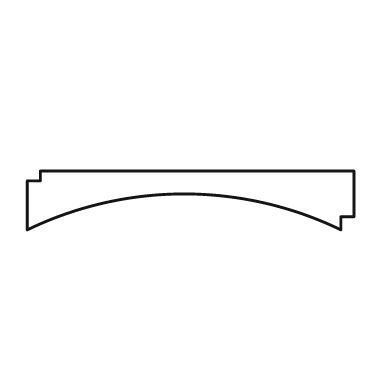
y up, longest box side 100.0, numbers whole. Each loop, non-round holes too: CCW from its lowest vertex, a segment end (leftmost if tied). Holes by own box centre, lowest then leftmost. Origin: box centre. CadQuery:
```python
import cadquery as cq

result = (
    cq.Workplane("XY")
    .moveTo(-50.0, -9.0)
    .threePointArc((-2.0, 2.0), (46.0, -9.0))
    .lineTo(46.0, -5.0)
    .lineTo(50.0, -5.0)
    .lineTo(50.0, 9.0)
    .lineTo(-46.0, 9.0)
    .lineTo(-46.0, 6.0)
    .lineTo(-50.0, 6.0)
    .close()
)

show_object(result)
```